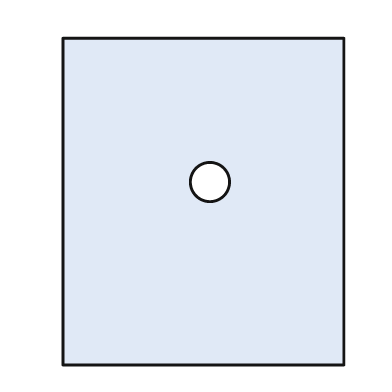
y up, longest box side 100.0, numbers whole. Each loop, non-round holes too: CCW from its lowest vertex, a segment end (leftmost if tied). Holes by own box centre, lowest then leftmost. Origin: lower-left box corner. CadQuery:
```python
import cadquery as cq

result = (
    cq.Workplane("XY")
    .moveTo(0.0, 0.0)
    .lineTo(86.0, 0.0)
    .lineTo(86.0, 100.0)
    .lineTo(0.0, 100.0)
    .close()
    .moveTo(45.0, 56.0)
    .circle(6.0)
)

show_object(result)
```